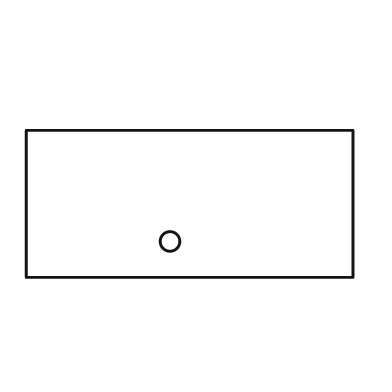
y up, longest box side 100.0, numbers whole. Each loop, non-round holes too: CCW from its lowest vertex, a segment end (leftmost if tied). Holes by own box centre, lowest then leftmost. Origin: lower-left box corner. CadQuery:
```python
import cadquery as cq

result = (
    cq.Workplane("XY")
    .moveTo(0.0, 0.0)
    .lineTo(100.0, 0.0)
    .lineTo(100.0, 45.0)
    .lineTo(0.0, 45.0)
    .close()
    .moveTo(44.0, 11.0)
    .circle(3.0)
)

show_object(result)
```